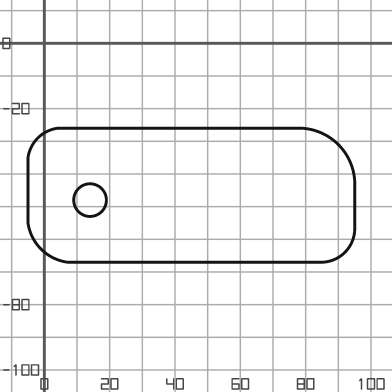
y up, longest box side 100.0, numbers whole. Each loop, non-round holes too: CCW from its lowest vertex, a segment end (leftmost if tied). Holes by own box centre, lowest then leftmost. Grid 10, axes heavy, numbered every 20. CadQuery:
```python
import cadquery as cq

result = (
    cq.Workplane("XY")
    .moveTo(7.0, -67.0)
    .lineTo(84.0, -67.0)
    .threePointArc((92.0, -64.0), (95.0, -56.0))
    .lineTo(95.0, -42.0)
    .threePointArc((90.0, -31.0), (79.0, -26.0))
    .lineTo(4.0, -26.0)
    .threePointArc((-2.0, -29.0), (-5.0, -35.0))
    .lineTo(-5.0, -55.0)
    .threePointArc((-1.0, -63.0), (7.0, -67.0))
    .close()
    .moveTo(14.0, -48.0)
    .circle(5.0)
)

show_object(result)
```